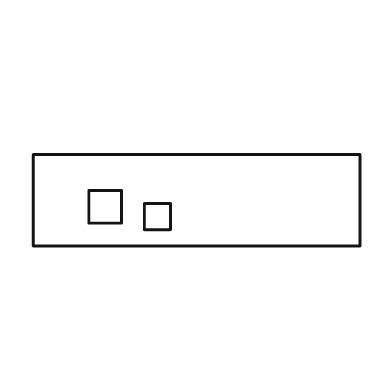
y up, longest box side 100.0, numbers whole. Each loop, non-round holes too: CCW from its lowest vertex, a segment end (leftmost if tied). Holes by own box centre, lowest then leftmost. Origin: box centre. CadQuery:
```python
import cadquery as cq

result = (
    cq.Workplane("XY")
    .moveTo(-50.0, -14.0)
    .lineTo(50.0, -14.0)
    .lineTo(50.0, 14.0)
    .lineTo(-50.0, 14.0)
    .close()
    .moveTo(-16.0, -9.0)
    .lineTo(-8.0, -9.0)
    .lineTo(-8.0, -1.0)
    .lineTo(-16.0, -1.0)
    .close()
    .moveTo(-33.0, -7.0)
    .lineTo(-23.0, -7.0)
    .lineTo(-23.0, 3.0)
    .lineTo(-33.0, 3.0)
    .close()
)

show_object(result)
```